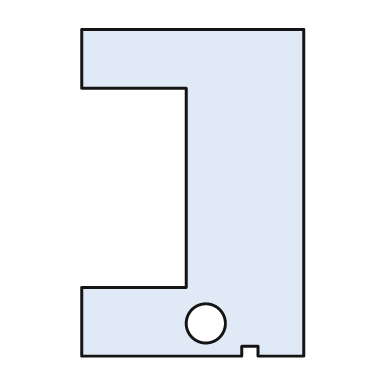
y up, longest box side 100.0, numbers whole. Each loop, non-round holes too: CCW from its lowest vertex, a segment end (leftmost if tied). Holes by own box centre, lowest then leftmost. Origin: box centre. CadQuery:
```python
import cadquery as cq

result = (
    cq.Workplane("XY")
    .moveTo(-34.0, -50.0)
    .lineTo(15.0, -50.0)
    .lineTo(15.0, -47.0)
    .lineTo(20.0, -47.0)
    .lineTo(20.0, -50.0)
    .lineTo(34.0, -50.0)
    .lineTo(34.0, 50.0)
    .lineTo(-34.0, 50.0)
    .lineTo(-34.0, 32.0)
    .lineTo(-2.0, 32.0)
    .lineTo(-2.0, -29.0)
    .lineTo(-34.0, -29.0)
    .close()
    .moveTo(4.0, -40.0)
    .circle(6.0)
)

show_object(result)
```